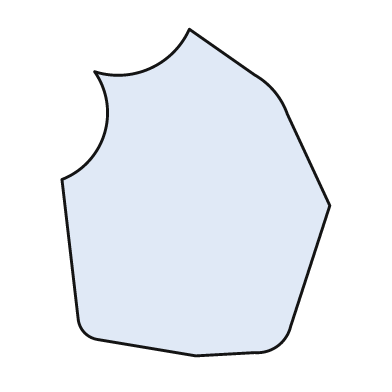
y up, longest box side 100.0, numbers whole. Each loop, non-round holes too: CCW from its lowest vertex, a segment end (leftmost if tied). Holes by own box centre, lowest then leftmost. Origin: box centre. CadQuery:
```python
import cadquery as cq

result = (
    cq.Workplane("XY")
    .moveTo(0.0, -50.0)
    .lineTo(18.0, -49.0)
    .threePointArc((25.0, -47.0), (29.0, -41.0))
    .lineTo(41.0, -4.0)
    .lineTo(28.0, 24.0)
    .threePointArc((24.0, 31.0), (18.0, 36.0))
    .lineTo(-2.0, 50.0)
    .threePointArc((-14.0, 38.0), (-31.0, 37.0))
    .threePointArc((-28.0, 18.0), (-41.0, 4.0))
    .lineTo(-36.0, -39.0)
    .threePointArc((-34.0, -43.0), (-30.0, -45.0))
    .close()
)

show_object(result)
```